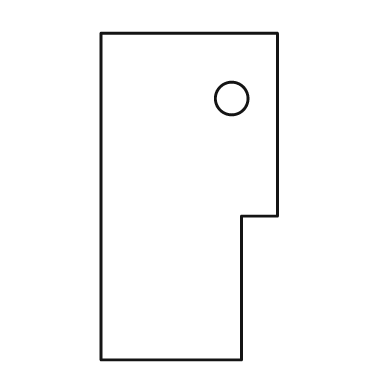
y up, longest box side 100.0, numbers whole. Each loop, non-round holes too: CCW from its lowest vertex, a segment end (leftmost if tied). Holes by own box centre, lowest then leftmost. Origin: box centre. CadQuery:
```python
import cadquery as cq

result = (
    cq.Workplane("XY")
    .moveTo(-27.0, -50.0)
    .lineTo(16.0, -50.0)
    .lineTo(16.0, -6.0)
    .lineTo(27.0, -6.0)
    .lineTo(27.0, 50.0)
    .lineTo(-27.0, 50.0)
    .close()
    .moveTo(13.0, 30.0)
    .circle(5.0)
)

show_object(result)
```